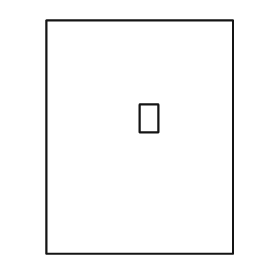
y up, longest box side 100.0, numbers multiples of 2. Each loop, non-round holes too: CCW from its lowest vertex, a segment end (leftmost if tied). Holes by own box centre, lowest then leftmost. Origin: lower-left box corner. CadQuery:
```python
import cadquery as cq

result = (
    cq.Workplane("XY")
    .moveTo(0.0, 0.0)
    .lineTo(80.0, 0.0)
    .lineTo(80.0, 100.0)
    .lineTo(0.0, 100.0)
    .close()
    .moveTo(40.0, 52.0)
    .lineTo(48.0, 52.0)
    .lineTo(48.0, 64.0)
    .lineTo(40.0, 64.0)
    .close()
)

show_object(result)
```